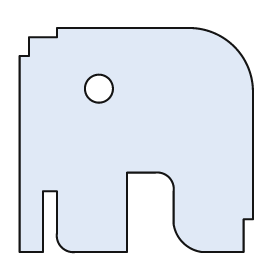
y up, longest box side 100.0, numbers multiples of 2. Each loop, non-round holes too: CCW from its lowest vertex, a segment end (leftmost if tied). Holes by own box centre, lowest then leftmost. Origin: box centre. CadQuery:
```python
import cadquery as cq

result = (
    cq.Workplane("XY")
    .moveTo(-50.0, -48.0)
    .lineTo(-40.0, -48.0)
    .lineTo(-40.0, -22.0)
    .lineTo(-34.0, -22.0)
    .lineTo(-34.0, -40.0)
    .threePointArc((-32.0, -46.0), (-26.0, -48.0))
    .lineTo(-4.0, -48.0)
    .lineTo(-4.0, -14.0)
    .lineTo(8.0, -14.0)
    .threePointArc((14.0, -16.0), (16.0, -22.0))
    .lineTo(16.0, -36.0)
    .threePointArc((20.0, -44.0), (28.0, -48.0))
    .lineTo(46.0, -48.0)
    .lineTo(46.0, -34.0)
    .lineTo(50.0, -34.0)
    .lineTo(50.0, 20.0)
    .threePointArc((42.0, 40.0), (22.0, 48.0))
    .lineTo(-34.0, 48.0)
    .lineTo(-34.0, 44.0)
    .lineTo(-46.0, 44.0)
    .lineTo(-46.0, 36.0)
    .lineTo(-50.0, 36.0)
    .close()
    .moveTo(-16.0, 22.0)
    .circle(6.0)
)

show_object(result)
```